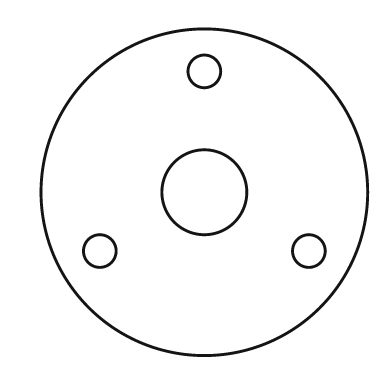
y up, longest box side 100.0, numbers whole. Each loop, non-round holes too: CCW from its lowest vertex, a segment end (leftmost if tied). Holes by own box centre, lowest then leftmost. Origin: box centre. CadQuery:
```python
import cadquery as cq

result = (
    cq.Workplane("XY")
    .moveTo(0.0, 0.0)
    .circle(50.0)
    .moveTo(-32.0, -18.0)
    .circle(5.0)
    .moveTo(32.0, -18.0)
    .circle(5.0)
    .moveTo(0.0, 0.0)
    .circle(13.0)
    .moveTo(0.0, 37.0)
    .circle(5.0)
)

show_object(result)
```